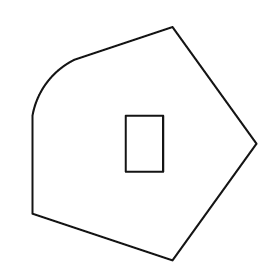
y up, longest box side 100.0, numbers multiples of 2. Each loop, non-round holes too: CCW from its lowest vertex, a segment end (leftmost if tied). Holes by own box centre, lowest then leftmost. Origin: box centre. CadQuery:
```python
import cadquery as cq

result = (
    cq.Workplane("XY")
    .moveTo(12.0, -50.0)
    .lineTo(48.0, 0.0)
    .lineTo(12.0, 50.0)
    .lineTo(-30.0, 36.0)
    .threePointArc((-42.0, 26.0), (-48.0, 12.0))
    .lineTo(-48.0, -30.0)
    .close()
    .moveTo(-8.0, -12.0)
    .lineTo(8.0, -12.0)
    .lineTo(8.0, 12.0)
    .lineTo(-8.0, 12.0)
    .close()
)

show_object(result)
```